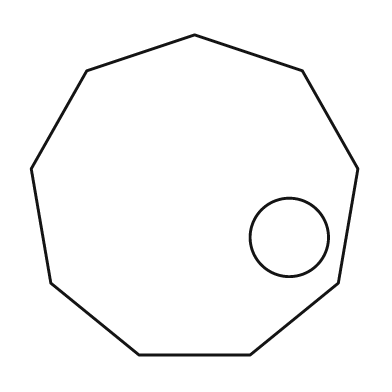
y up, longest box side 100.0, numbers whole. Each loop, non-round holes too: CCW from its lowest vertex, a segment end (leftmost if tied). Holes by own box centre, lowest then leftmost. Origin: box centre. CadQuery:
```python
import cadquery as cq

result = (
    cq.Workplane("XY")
    .moveTo(-17.0, -49.0)
    .lineTo(17.0, -49.0)
    .lineTo(44.0, -27.0)
    .lineTo(50.0, 8.0)
    .lineTo(33.0, 38.0)
    .lineTo(0.0, 49.0)
    .lineTo(-33.0, 38.0)
    .lineTo(-50.0, 8.0)
    .lineTo(-44.0, -27.0)
    .close()
    .moveTo(29.0, -13.0)
    .circle(12.0)
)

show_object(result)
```